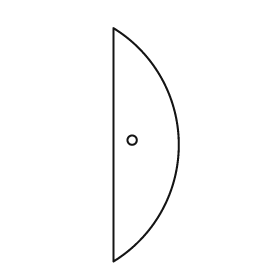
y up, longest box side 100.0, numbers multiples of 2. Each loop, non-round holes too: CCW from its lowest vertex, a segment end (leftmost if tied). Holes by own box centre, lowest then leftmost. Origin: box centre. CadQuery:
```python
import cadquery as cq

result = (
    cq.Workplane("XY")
    .moveTo(-14.0, -50.0)
    .threePointArc((14.0, 0.0), (-14.0, 50.0))
    .close()
    .moveTo(-6.0, 2.0)
    .circle(2.0)
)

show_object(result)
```